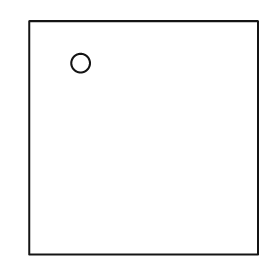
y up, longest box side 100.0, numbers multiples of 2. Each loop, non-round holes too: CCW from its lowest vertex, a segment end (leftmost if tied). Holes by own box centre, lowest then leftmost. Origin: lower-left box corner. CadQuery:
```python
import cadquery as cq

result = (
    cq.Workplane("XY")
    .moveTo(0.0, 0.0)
    .lineTo(98.0, 0.0)
    .lineTo(98.0, 100.0)
    .lineTo(0.0, 100.0)
    .close()
    .moveTo(22.0, 82.0)
    .circle(4.0)
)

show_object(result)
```